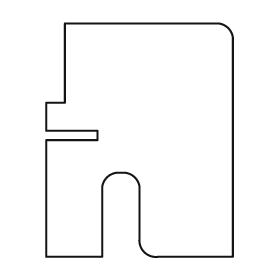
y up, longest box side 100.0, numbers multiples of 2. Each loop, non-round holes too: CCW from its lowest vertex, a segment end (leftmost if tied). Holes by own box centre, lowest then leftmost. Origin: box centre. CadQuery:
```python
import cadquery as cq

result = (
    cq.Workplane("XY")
    .moveTo(-40.0, -50.0)
    .lineTo(-16.0, -50.0)
    .lineTo(-16.0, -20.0)
    .threePointArc((-14.0, -16.0), (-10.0, -14.0))
    .lineTo(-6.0, -14.0)
    .threePointArc((-2.0, -16.0), (0.0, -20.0))
    .lineTo(0.0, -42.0)
    .threePointArc((2.0, -48.0), (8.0, -50.0))
    .lineTo(40.0, -50.0)
    .lineTo(40.0, 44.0)
    .threePointArc((38.0, 48.0), (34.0, 50.0))
    .lineTo(-32.0, 50.0)
    .lineTo(-32.0, 16.0)
    .lineTo(-40.0, 16.0)
    .lineTo(-40.0, 4.0)
    .lineTo(-18.0, 4.0)
    .lineTo(-18.0, 0.0)
    .lineTo(-40.0, 0.0)
    .close()
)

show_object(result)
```